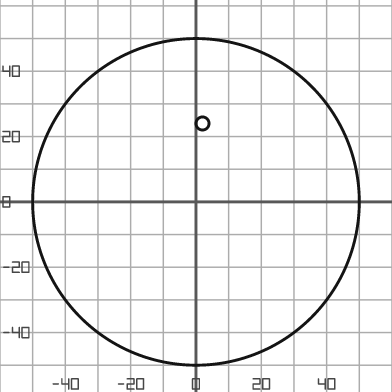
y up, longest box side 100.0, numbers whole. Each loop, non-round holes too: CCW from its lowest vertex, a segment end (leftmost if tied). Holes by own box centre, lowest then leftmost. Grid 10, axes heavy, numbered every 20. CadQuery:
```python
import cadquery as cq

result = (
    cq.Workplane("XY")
    .moveTo(0.0, 0.0)
    .circle(50.0)
    .moveTo(2.0, 24.0)
    .circle(2.0)
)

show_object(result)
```